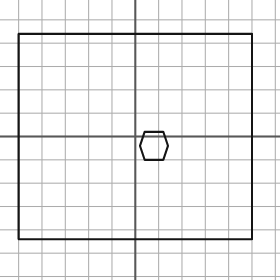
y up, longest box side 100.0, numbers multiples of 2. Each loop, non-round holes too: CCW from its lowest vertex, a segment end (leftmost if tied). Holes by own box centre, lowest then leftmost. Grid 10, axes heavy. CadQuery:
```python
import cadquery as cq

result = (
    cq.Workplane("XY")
    .moveTo(-50.0, -44.0)
    .lineTo(50.0, -44.0)
    .lineTo(50.0, 44.0)
    .lineTo(-50.0, 44.0)
    .close()
    .moveTo(4.0, -10.0)
    .lineTo(12.0, -10.0)
    .lineTo(14.0, -4.0)
    .lineTo(12.0, 2.0)
    .lineTo(4.0, 2.0)
    .lineTo(2.0, -4.0)
    .close()
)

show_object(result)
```